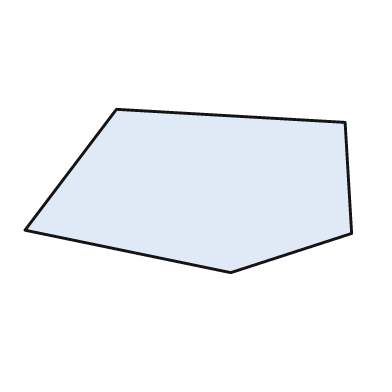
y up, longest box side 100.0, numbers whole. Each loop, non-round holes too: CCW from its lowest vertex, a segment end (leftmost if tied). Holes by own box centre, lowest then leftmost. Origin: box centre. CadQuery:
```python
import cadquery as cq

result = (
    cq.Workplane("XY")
    .moveTo(13.0, -25.0)
    .lineTo(50.0, -13.0)
    .lineTo(48.0, 21.0)
    .lineTo(-22.0, 25.0)
    .lineTo(-50.0, -12.0)
    .close()
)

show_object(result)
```